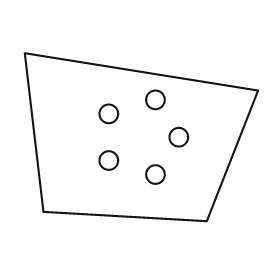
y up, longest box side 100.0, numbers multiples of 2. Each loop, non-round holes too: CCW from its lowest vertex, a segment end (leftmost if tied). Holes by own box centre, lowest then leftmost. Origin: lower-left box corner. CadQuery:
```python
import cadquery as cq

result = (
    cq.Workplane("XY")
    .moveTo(78.0, 0.0)
    .lineTo(100.0, 56.0)
    .lineTo(0.0, 72.0)
    .lineTo(8.0, 4.0)
    .close()
    .moveTo(56.0, 20.0)
    .circle(4.0)
    .moveTo(36.0, 26.0)
    .circle(4.0)
    .moveTo(66.0, 36.0)
    .circle(4.0)
    .moveTo(36.0, 46.0)
    .circle(4.0)
    .moveTo(56.0, 52.0)
    .circle(4.0)
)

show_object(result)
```